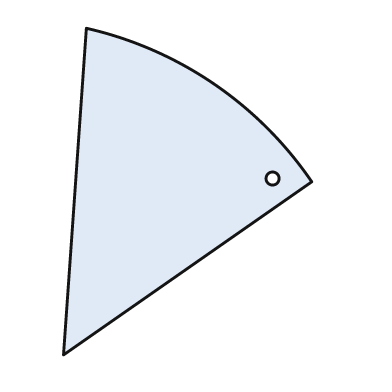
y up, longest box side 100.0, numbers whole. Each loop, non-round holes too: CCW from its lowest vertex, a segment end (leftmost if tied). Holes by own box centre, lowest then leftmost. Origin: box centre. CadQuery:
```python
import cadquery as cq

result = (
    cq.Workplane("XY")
    .moveTo(-38.0, -50.0)
    .lineTo(38.0, 3.0)
    .threePointArc((8.0, 33.0), (-31.0, 50.0))
    .close()
    .moveTo(26.0, 4.0)
    .circle(2.0)
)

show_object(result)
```